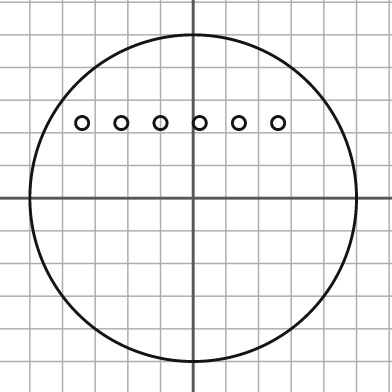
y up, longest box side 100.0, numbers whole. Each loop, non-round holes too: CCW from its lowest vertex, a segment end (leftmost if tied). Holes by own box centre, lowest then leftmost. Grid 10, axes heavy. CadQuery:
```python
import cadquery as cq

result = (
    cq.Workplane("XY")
    .moveTo(0.0, 0.0)
    .circle(50.0)
    .moveTo(-34.0, 23.0)
    .circle(2.0)
    .moveTo(-22.0, 23.0)
    .circle(2.0)
    .moveTo(-10.0, 23.0)
    .circle(2.0)
    .moveTo(2.0, 23.0)
    .circle(2.0)
    .moveTo(14.0, 23.0)
    .circle(2.0)
    .moveTo(26.0, 23.0)
    .circle(2.0)
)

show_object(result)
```